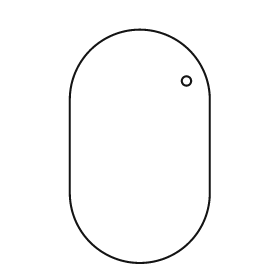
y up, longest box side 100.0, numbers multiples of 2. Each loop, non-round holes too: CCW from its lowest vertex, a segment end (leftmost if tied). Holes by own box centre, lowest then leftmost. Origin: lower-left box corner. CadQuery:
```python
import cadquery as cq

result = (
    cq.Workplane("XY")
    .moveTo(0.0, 30.0)
    .threePointArc((30.0, 0.0), (60.0, 30.0))
    .lineTo(60.0, 70.0)
    .threePointArc((30.0, 100.0), (0.0, 70.0))
    .close()
    .moveTo(50.0, 78.0)
    .circle(2.0)
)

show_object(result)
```